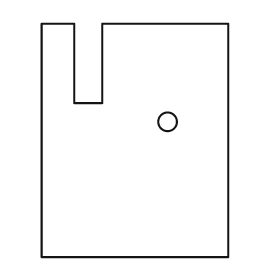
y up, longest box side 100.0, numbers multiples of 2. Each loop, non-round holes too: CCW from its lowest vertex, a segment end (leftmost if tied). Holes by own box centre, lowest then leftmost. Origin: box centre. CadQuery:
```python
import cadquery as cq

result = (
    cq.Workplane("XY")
    .moveTo(-40.0, -50.0)
    .lineTo(40.0, -50.0)
    .lineTo(40.0, 50.0)
    .lineTo(-14.0, 50.0)
    .lineTo(-14.0, 16.0)
    .lineTo(-26.0, 16.0)
    .lineTo(-26.0, 50.0)
    .lineTo(-40.0, 50.0)
    .close()
    .moveTo(14.0, 8.0)
    .circle(4.0)
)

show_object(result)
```